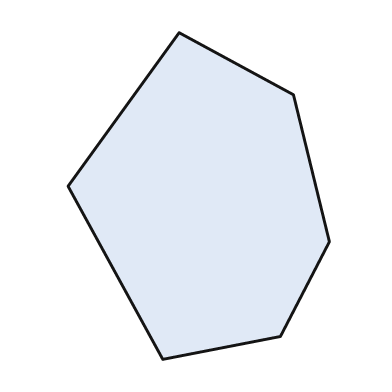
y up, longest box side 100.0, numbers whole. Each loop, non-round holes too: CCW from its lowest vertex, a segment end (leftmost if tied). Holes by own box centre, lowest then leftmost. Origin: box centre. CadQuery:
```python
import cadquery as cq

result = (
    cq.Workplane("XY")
    .moveTo(-11.0, -50.0)
    .lineTo(25.0, -43.0)
    .lineTo(40.0, -14.0)
    .lineTo(29.0, 31.0)
    .lineTo(-6.0, 50.0)
    .lineTo(-40.0, 3.0)
    .close()
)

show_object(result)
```